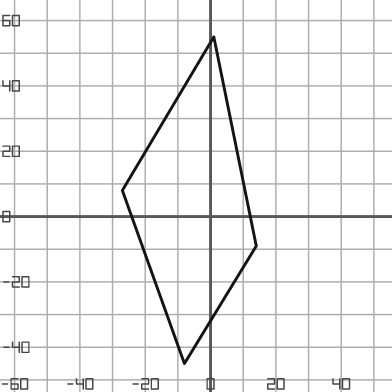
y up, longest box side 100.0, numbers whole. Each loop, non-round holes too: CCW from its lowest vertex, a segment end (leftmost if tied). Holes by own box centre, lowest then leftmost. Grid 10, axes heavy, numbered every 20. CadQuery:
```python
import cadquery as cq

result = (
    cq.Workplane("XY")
    .moveTo(-8.0, -45.0)
    .lineTo(14.0, -9.0)
    .lineTo(1.0, 55.0)
    .lineTo(-27.0, 8.0)
    .close()
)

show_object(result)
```